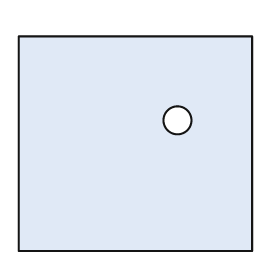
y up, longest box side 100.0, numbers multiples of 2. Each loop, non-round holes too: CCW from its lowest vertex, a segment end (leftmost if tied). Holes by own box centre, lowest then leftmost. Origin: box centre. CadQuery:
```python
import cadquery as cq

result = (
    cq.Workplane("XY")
    .moveTo(-50.0, -46.0)
    .lineTo(50.0, -46.0)
    .lineTo(50.0, 46.0)
    .lineTo(-50.0, 46.0)
    .close()
    .moveTo(18.0, 10.0)
    .circle(6.0)
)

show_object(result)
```